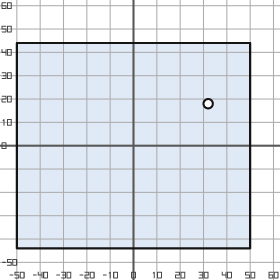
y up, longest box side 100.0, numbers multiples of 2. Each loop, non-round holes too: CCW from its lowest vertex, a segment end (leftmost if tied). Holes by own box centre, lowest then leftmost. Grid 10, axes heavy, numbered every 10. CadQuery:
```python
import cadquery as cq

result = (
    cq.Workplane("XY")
    .moveTo(-50.0, -44.0)
    .lineTo(50.0, -44.0)
    .lineTo(50.0, 44.0)
    .lineTo(-50.0, 44.0)
    .close()
    .moveTo(32.0, 18.0)
    .circle(2.0)
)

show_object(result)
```